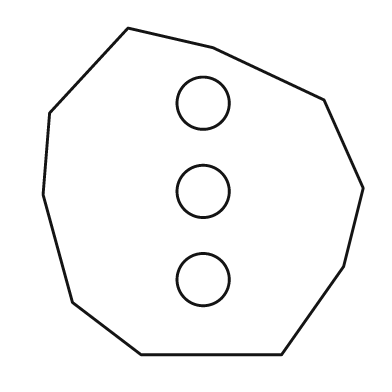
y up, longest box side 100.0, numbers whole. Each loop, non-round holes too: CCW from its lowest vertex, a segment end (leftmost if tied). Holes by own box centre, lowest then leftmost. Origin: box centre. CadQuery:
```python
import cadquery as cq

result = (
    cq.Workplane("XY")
    .moveTo(-19.0, -50.0)
    .lineTo(24.0, -50.0)
    .lineTo(43.0, -23.0)
    .lineTo(49.0, 1.0)
    .lineTo(37.0, 28.0)
    .lineTo(3.0, 44.0)
    .lineTo(-23.0, 50.0)
    .lineTo(-47.0, 24.0)
    .lineTo(-49.0, -1.0)
    .lineTo(-40.0, -34.0)
    .close()
    .moveTo(0.0, -27.0)
    .circle(8.0)
    .moveTo(0.0, 0.0)
    .circle(8.0)
    .moveTo(0.0, 27.0)
    .circle(8.0)
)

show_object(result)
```